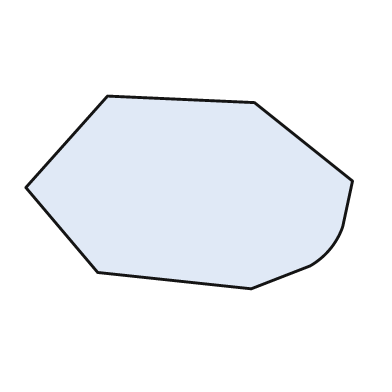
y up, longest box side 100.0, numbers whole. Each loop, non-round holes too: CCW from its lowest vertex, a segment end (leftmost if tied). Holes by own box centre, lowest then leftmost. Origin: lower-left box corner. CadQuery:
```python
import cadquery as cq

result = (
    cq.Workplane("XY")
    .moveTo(69.0, 0.0)
    .lineTo(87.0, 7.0)
    .threePointArc((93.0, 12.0), (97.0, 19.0))
    .lineTo(100.0, 33.0)
    .lineTo(70.0, 57.0)
    .lineTo(25.0, 59.0)
    .lineTo(0.0, 31.0)
    .lineTo(22.0, 5.0)
    .close()
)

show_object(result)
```